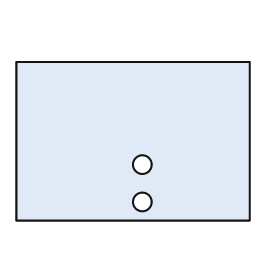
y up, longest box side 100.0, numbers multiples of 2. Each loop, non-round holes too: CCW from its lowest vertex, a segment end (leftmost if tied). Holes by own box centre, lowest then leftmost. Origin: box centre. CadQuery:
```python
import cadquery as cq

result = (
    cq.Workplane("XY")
    .moveTo(-50.0, -34.0)
    .lineTo(50.0, -34.0)
    .lineTo(50.0, 34.0)
    .lineTo(-50.0, 34.0)
    .close()
    .moveTo(4.0, -26.0)
    .circle(4.0)
    .moveTo(4.0, -10.0)
    .circle(4.0)
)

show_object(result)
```